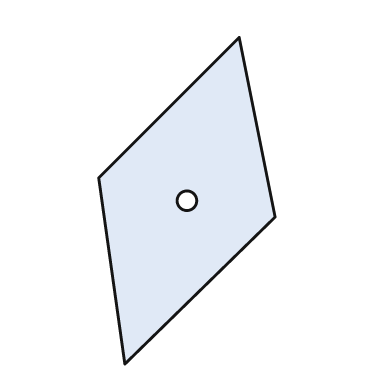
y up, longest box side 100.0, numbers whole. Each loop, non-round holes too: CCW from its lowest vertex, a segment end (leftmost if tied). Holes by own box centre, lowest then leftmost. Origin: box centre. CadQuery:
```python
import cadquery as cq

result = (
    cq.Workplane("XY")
    .moveTo(-19.0, -50.0)
    .lineTo(27.0, -5.0)
    .lineTo(16.0, 50.0)
    .lineTo(-27.0, 7.0)
    .close()
    .moveTo(0.0, 0.0)
    .circle(3.0)
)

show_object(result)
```